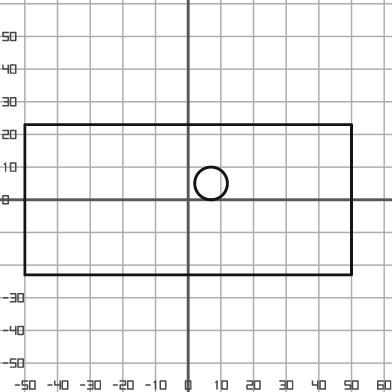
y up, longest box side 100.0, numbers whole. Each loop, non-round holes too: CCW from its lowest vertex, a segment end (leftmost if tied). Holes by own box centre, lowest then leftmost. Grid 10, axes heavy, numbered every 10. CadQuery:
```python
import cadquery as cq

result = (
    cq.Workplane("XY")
    .moveTo(-50.0, -23.0)
    .lineTo(50.0, -23.0)
    .lineTo(50.0, 23.0)
    .lineTo(-50.0, 23.0)
    .close()
    .moveTo(7.0, 5.0)
    .circle(5.0)
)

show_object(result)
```